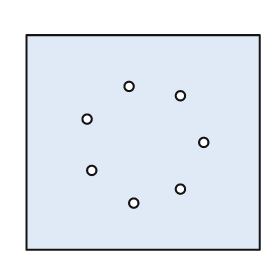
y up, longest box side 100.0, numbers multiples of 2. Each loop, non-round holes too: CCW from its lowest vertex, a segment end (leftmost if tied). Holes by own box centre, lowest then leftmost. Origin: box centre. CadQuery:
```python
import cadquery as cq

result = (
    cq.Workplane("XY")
    .moveTo(-50.0, -46.0)
    .lineTo(50.0, -46.0)
    .lineTo(50.0, 46.0)
    .lineTo(-50.0, 46.0)
    .close()
    .moveTo(-4.0, -26.0)
    .circle(2.0)
    .moveTo(16.0, -20.0)
    .circle(2.0)
    .moveTo(-22.0, -12.0)
    .circle(2.0)
    .moveTo(26.0, 0.0)
    .circle(2.0)
    .moveTo(-24.0, 10.0)
    .circle(2.0)
    .moveTo(16.0, 20.0)
    .circle(2.0)
    .moveTo(-6.0, 24.0)
    .circle(2.0)
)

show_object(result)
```